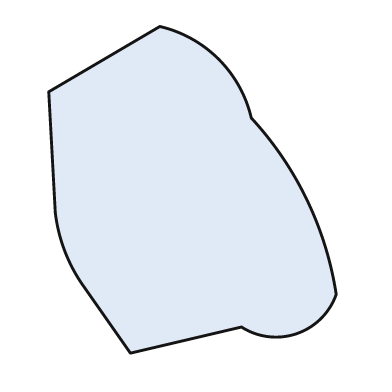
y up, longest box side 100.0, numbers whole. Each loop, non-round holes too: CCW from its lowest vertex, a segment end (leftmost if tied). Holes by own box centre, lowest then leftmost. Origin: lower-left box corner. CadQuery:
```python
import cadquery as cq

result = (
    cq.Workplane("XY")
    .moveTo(25.0, 0.0)
    .lineTo(59.0, 8.0)
    .threePointArc((76.0, 6.0), (88.0, 18.0))
    .threePointArc((79.0, 47.0), (62.0, 72.0))
    .threePointArc((52.0, 90.0), (34.0, 100.0))
    .lineTo(0.0, 80.0)
    .lineTo(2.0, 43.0)
    .threePointArc((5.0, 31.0), (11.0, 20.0))
    .close()
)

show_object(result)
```